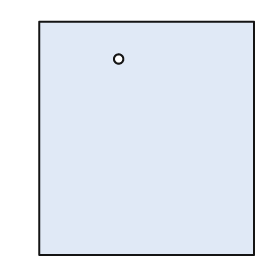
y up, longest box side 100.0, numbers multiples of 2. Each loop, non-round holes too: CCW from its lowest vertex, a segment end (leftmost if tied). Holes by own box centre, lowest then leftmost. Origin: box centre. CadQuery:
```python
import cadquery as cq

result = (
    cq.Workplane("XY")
    .moveTo(-46.0, -50.0)
    .lineTo(46.0, -50.0)
    .lineTo(46.0, 50.0)
    .lineTo(-46.0, 50.0)
    .close()
    .moveTo(-12.0, 34.0)
    .circle(2.0)
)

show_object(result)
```